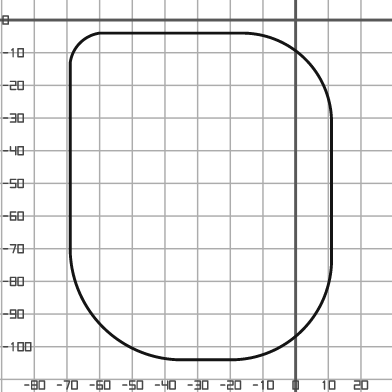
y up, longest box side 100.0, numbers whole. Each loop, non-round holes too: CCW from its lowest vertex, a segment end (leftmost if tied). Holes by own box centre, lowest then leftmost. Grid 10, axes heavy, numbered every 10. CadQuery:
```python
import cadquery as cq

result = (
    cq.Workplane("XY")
    .moveTo(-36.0, -104.0)
    .lineTo(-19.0, -104.0)
    .threePointArc((2.0, -95.0), (11.0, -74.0))
    .lineTo(11.0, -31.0)
    .threePointArc((3.0, -12.0), (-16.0, -4.0))
    .lineTo(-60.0, -4.0)
    .threePointArc((-66.0, -7.0), (-69.0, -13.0))
    .lineTo(-69.0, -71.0)
    .threePointArc((-59.0, -94.0), (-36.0, -104.0))
    .close()
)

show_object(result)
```